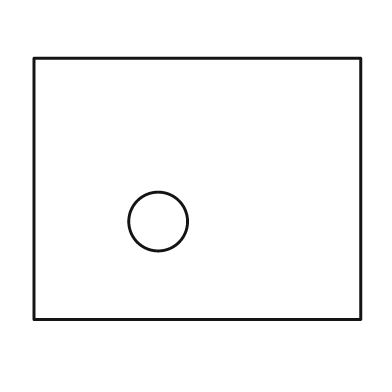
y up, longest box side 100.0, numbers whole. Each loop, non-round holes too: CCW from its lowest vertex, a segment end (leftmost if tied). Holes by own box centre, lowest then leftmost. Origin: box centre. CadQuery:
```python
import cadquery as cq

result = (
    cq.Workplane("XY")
    .moveTo(-50.0, -40.0)
    .lineTo(50.0, -40.0)
    .lineTo(50.0, 40.0)
    .lineTo(-50.0, 40.0)
    .close()
    .moveTo(-12.0, -10.0)
    .circle(9.0)
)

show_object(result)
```